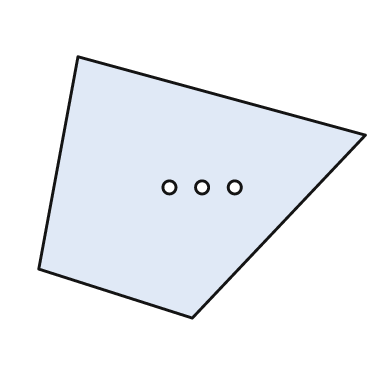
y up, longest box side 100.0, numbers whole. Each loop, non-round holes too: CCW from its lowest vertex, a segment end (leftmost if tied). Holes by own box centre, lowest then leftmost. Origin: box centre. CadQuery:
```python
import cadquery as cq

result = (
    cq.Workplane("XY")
    .moveTo(-3.0, -40.0)
    .lineTo(50.0, 16.0)
    .lineTo(-38.0, 40.0)
    .lineTo(-50.0, -25.0)
    .close()
    .moveTo(-10.0, 0.0)
    .circle(2.0)
    .moveTo(0.0, 0.0)
    .circle(2.0)
    .moveTo(10.0, 0.0)
    .circle(2.0)
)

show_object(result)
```